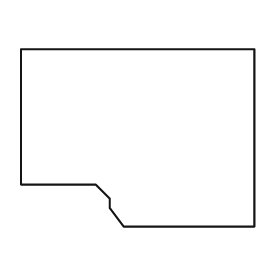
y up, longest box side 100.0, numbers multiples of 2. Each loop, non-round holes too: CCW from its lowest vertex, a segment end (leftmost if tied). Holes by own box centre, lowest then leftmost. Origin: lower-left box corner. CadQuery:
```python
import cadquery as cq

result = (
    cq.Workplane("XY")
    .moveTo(44.0, 0.0)
    .lineTo(100.0, 0.0)
    .lineTo(100.0, 76.0)
    .lineTo(0.0, 76.0)
    .lineTo(0.0, 18.0)
    .lineTo(32.0, 18.0)
    .lineTo(38.0, 12.0)
    .lineTo(38.0, 8.0)
    .close()
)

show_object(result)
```